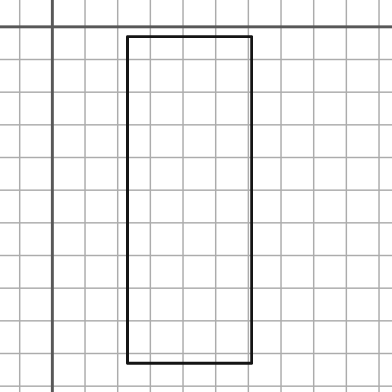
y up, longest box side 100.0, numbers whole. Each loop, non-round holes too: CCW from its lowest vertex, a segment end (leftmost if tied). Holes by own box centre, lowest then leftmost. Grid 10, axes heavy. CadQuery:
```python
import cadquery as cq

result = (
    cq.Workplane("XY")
    .moveTo(23.0, -103.0)
    .lineTo(61.0, -103.0)
    .lineTo(61.0, -3.0)
    .lineTo(23.0, -3.0)
    .close()
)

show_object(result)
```